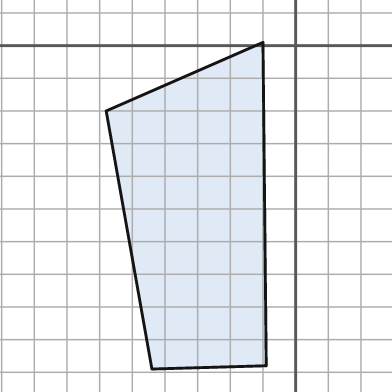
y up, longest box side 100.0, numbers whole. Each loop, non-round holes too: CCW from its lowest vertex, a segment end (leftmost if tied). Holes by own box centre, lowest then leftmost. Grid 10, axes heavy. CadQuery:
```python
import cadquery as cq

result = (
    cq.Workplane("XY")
    .moveTo(-44.0, -99.0)
    .lineTo(-9.0, -98.0)
    .lineTo(-10.0, 1.0)
    .lineTo(-58.0, -20.0)
    .close()
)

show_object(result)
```